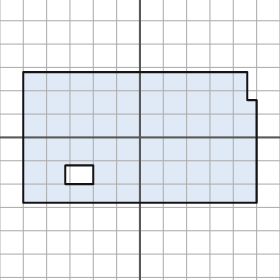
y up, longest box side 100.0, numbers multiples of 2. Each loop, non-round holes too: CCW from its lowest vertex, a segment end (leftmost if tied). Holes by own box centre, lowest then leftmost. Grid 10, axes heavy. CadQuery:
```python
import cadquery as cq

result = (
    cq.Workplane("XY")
    .moveTo(-50.0, -28.0)
    .lineTo(50.0, -28.0)
    .lineTo(50.0, 16.0)
    .lineTo(46.0, 16.0)
    .lineTo(46.0, 28.0)
    .lineTo(-50.0, 28.0)
    .close()
    .moveTo(-32.0, -20.0)
    .lineTo(-20.0, -20.0)
    .lineTo(-20.0, -12.0)
    .lineTo(-32.0, -12.0)
    .close()
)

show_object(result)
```